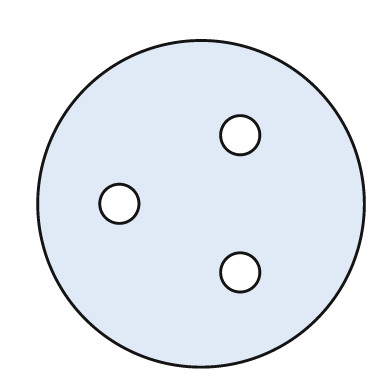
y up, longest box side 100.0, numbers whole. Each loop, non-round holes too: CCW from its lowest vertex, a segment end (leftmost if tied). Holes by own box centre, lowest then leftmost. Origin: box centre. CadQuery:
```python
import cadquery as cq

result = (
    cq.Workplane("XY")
    .moveTo(0.0, 0.0)
    .circle(50.0)
    .moveTo(12.0, -21.0)
    .circle(6.0)
    .moveTo(-25.0, 0.0)
    .circle(6.0)
    .moveTo(12.0, 21.0)
    .circle(6.0)
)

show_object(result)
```